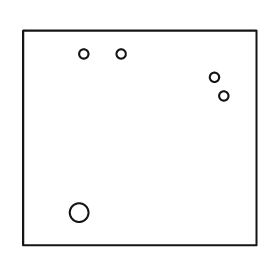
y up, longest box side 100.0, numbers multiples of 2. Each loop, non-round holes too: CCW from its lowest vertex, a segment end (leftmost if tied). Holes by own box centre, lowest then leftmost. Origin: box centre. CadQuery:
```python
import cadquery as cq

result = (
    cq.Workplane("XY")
    .moveTo(-50.0, -46.0)
    .lineTo(50.0, -46.0)
    .lineTo(50.0, 46.0)
    .lineTo(-50.0, 46.0)
    .close()
    .moveTo(-26.0, -32.0)
    .circle(4.0)
    .moveTo(36.0, 18.0)
    .circle(2.0)
    .moveTo(32.0, 26.0)
    .circle(2.0)
    .moveTo(-24.0, 36.0)
    .circle(2.0)
    .moveTo(-8.0, 36.0)
    .circle(2.0)
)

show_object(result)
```